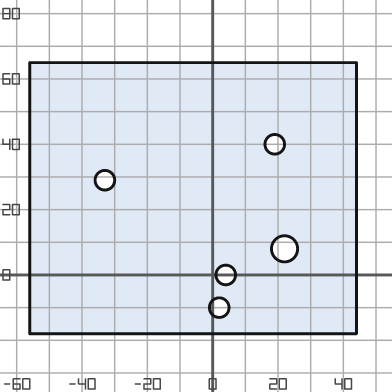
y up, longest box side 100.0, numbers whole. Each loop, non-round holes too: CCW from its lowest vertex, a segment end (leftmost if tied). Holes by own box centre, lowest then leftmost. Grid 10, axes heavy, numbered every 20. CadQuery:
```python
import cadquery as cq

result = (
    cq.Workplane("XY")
    .moveTo(-56.0, -18.0)
    .lineTo(44.0, -18.0)
    .lineTo(44.0, 65.0)
    .lineTo(-56.0, 65.0)
    .close()
    .moveTo(2.0, -10.0)
    .circle(3.0)
    .moveTo(4.0, 0.0)
    .circle(3.0)
    .moveTo(22.0, 8.0)
    .circle(4.0)
    .moveTo(-33.0, 29.0)
    .circle(3.0)
    .moveTo(19.0, 40.0)
    .circle(3.0)
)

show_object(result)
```